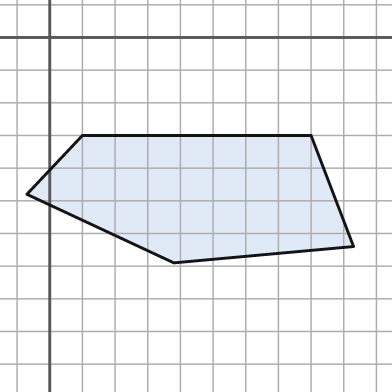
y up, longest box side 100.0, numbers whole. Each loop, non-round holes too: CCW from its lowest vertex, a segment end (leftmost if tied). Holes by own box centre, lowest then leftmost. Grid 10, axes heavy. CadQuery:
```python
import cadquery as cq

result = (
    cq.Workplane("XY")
    .moveTo(38.0, -69.0)
    .lineTo(93.0, -64.0)
    .lineTo(80.0, -30.0)
    .lineTo(10.0, -30.0)
    .lineTo(-7.0, -48.0)
    .close()
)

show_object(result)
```